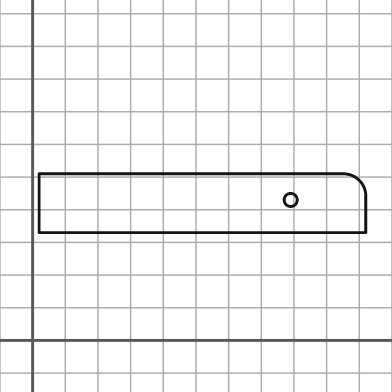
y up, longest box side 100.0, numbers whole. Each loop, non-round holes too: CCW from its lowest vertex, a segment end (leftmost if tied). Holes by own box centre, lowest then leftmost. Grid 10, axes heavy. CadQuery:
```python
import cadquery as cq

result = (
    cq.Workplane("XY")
    .moveTo(2.0, 33.0)
    .lineTo(102.0, 33.0)
    .lineTo(102.0, 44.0)
    .threePointArc((100.0, 49.0), (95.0, 51.0))
    .lineTo(2.0, 51.0)
    .close()
    .moveTo(79.0, 43.0)
    .circle(2.0)
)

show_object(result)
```